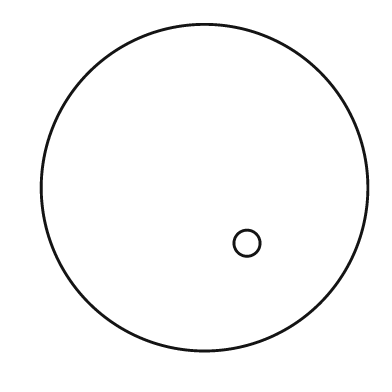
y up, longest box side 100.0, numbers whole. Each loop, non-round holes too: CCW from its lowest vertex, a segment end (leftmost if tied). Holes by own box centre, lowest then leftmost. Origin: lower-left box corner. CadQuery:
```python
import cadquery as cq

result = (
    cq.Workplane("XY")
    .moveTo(50.0, 50.0)
    .circle(50.0)
    .moveTo(63.0, 33.0)
    .circle(4.0)
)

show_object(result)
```